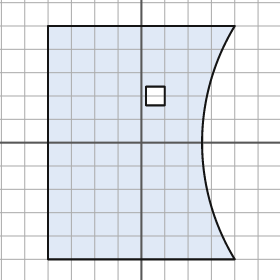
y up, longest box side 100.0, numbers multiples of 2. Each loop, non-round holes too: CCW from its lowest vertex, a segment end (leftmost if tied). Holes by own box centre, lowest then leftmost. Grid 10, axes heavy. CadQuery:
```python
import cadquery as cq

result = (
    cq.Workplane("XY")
    .moveTo(-40.0, -50.0)
    .lineTo(40.0, -50.0)
    .threePointArc((26.0, 0.0), (40.0, 50.0))
    .lineTo(-40.0, 50.0)
    .close()
    .moveTo(2.0, 16.0)
    .lineTo(10.0, 16.0)
    .lineTo(10.0, 24.0)
    .lineTo(2.0, 24.0)
    .close()
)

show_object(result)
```